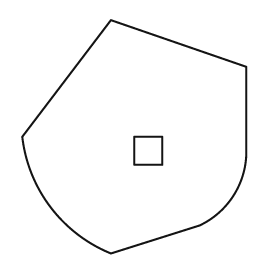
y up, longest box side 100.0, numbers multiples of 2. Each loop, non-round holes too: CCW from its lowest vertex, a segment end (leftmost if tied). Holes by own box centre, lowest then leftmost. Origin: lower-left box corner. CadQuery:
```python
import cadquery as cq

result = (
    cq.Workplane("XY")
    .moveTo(38.0, 0.0)
    .lineTo(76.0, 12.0)
    .threePointArc((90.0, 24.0), (96.0, 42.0))
    .lineTo(96.0, 80.0)
    .lineTo(38.0, 100.0)
    .lineTo(0.0, 50.0)
    .threePointArc((12.0, 20.0), (38.0, 0.0))
    .close()
    .moveTo(48.0, 38.0)
    .lineTo(60.0, 38.0)
    .lineTo(60.0, 50.0)
    .lineTo(48.0, 50.0)
    .close()
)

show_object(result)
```